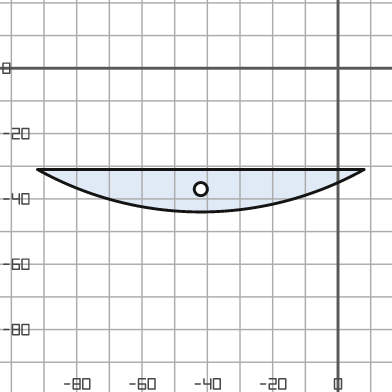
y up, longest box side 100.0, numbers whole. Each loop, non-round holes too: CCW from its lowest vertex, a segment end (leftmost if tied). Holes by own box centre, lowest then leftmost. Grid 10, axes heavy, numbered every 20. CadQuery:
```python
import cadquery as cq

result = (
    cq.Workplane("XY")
    .moveTo(-92.0, -31.0)
    .threePointArc((-42.0, -44.0), (8.0, -31.0))
    .close()
    .moveTo(-42.0, -37.0)
    .circle(2.0)
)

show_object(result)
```